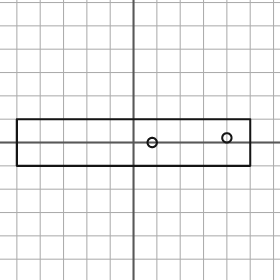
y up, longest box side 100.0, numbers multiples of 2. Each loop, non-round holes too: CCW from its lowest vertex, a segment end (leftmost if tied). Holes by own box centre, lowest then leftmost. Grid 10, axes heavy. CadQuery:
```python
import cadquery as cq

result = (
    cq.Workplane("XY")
    .moveTo(-50.0, -10.0)
    .lineTo(50.0, -10.0)
    .lineTo(50.0, 10.0)
    .lineTo(-50.0, 10.0)
    .close()
    .moveTo(8.0, 0.0)
    .circle(2.0)
    .moveTo(40.0, 2.0)
    .circle(2.0)
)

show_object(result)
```